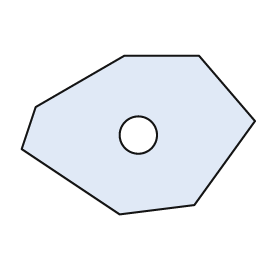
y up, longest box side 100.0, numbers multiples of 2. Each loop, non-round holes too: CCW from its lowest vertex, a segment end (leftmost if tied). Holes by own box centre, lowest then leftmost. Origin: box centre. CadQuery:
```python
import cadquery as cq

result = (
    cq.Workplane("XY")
    .moveTo(-8.0, -34.0)
    .lineTo(24.0, -30.0)
    .lineTo(50.0, 6.0)
    .lineTo(26.0, 34.0)
    .lineTo(-6.0, 34.0)
    .lineTo(-44.0, 12.0)
    .lineTo(-50.0, -6.0)
    .close()
    .moveTo(0.0, 0.0)
    .circle(8.0)
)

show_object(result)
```